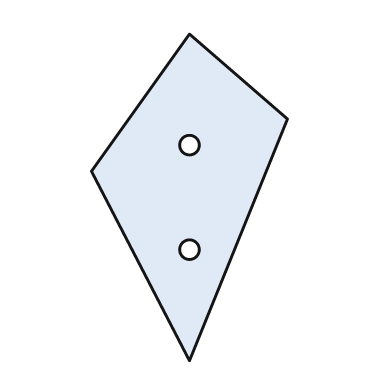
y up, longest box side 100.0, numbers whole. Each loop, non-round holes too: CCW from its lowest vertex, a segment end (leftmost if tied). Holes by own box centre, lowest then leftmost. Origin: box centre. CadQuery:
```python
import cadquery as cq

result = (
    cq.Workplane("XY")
    .moveTo(0.0, -50.0)
    .lineTo(30.0, 24.0)
    .lineTo(0.0, 50.0)
    .lineTo(-30.0, 8.0)
    .close()
    .moveTo(0.0, -16.0)
    .circle(3.0)
    .moveTo(0.0, 16.0)
    .circle(3.0)
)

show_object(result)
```